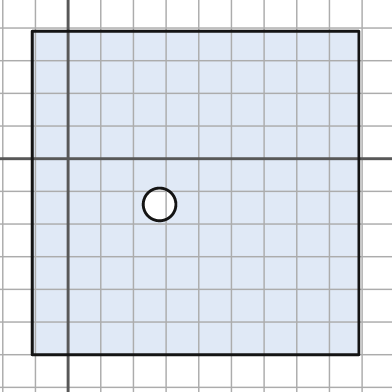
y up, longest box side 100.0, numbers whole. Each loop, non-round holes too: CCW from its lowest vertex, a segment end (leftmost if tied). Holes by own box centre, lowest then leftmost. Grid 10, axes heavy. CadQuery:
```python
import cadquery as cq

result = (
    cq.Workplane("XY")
    .moveTo(-11.0, -60.0)
    .lineTo(89.0, -60.0)
    .lineTo(89.0, 39.0)
    .lineTo(-11.0, 39.0)
    .close()
    .moveTo(28.0, -14.0)
    .circle(5.0)
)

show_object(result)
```